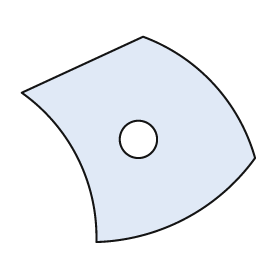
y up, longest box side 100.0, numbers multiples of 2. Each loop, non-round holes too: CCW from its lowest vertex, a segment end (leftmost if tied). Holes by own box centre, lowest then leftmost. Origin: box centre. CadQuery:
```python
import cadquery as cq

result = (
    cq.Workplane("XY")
    .moveTo(-18.0, -44.0)
    .threePointArc((20.0, -34.0), (50.0, -8.0))
    .threePointArc((32.0, 24.0), (2.0, 44.0))
    .lineTo(-50.0, 20.0)
    .threePointArc((-26.0, -8.0), (-18.0, -44.0))
    .close()
    .moveTo(0.0, 0.0)
    .circle(8.0)
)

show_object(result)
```